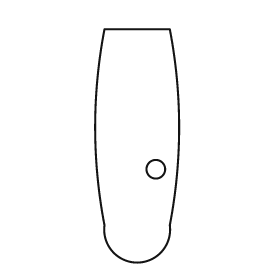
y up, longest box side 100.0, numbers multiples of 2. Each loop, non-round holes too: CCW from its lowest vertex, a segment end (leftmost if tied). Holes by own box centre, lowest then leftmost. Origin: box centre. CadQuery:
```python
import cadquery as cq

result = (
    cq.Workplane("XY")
    .moveTo(-14.0, -34.0)
    .threePointArc((0.0, -50.0), (14.0, -34.0))
    .threePointArc((18.0, 8.0), (14.0, 50.0))
    .lineTo(-14.0, 50.0)
    .threePointArc((-18.0, 8.0), (-14.0, -34.0))
    .close()
    .moveTo(8.0, -10.0)
    .circle(4.0)
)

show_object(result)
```